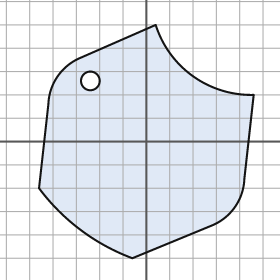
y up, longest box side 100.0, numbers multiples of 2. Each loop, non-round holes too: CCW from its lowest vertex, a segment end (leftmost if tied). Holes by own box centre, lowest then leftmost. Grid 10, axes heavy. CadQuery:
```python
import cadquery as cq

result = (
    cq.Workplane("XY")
    .moveTo(-6.0, -50.0)
    .lineTo(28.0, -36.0)
    .threePointArc((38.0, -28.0), (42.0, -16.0))
    .lineTo(46.0, 20.0)
    .threePointArc((20.0, 28.0), (4.0, 50.0))
    .lineTo(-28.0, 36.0)
    .threePointArc((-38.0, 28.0), (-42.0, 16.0))
    .lineTo(-46.0, -20.0)
    .threePointArc((-28.0, -38.0), (-6.0, -50.0))
    .close()
    .moveTo(-24.0, 26.0)
    .circle(4.0)
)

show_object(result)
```